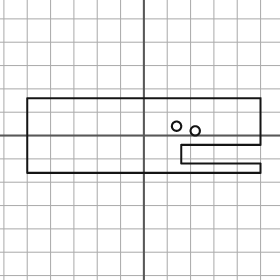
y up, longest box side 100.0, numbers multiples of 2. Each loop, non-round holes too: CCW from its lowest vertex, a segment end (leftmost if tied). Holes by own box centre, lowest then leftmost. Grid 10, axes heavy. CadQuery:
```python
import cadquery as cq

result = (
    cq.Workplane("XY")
    .moveTo(-50.0, -16.0)
    .lineTo(50.0, -16.0)
    .lineTo(50.0, -12.0)
    .lineTo(16.0, -12.0)
    .lineTo(16.0, -4.0)
    .lineTo(50.0, -4.0)
    .lineTo(50.0, 16.0)
    .lineTo(-50.0, 16.0)
    .close()
    .moveTo(22.0, 2.0)
    .circle(2.0)
    .moveTo(14.0, 4.0)
    .circle(2.0)
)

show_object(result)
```